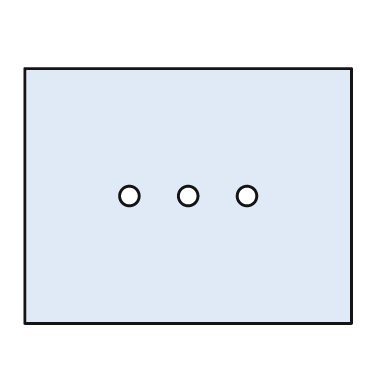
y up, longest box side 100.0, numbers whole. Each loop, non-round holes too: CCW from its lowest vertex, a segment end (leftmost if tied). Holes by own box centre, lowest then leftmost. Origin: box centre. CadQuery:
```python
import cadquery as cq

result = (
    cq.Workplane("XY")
    .moveTo(-50.0, -39.0)
    .lineTo(50.0, -39.0)
    .lineTo(50.0, 39.0)
    .lineTo(-50.0, 39.0)
    .close()
    .moveTo(-18.0, 0.0)
    .circle(3.0)
    .moveTo(0.0, 0.0)
    .circle(3.0)
    .moveTo(18.0, 0.0)
    .circle(3.0)
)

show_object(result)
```